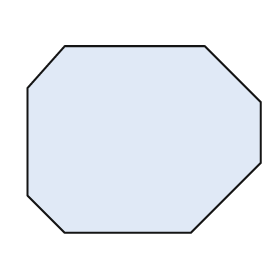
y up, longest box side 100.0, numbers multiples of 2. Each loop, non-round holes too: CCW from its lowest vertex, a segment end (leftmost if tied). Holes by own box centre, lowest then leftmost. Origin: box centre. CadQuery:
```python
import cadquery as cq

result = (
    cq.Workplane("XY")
    .moveTo(-34.0, -40.0)
    .lineTo(20.0, -40.0)
    .lineTo(50.0, -10.0)
    .lineTo(50.0, 16.0)
    .lineTo(26.0, 40.0)
    .lineTo(-34.0, 40.0)
    .lineTo(-50.0, 22.0)
    .lineTo(-50.0, -24.0)
    .close()
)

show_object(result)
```